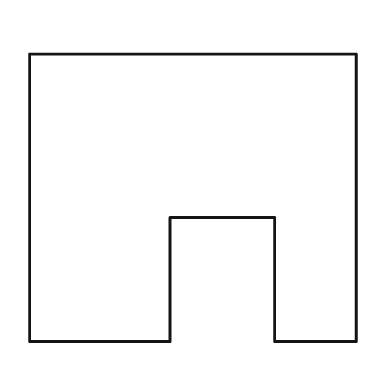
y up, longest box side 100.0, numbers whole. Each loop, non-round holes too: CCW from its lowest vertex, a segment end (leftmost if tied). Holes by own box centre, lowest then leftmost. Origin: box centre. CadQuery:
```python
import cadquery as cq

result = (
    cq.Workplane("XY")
    .moveTo(-50.0, -44.0)
    .lineTo(-7.0, -44.0)
    .lineTo(-7.0, -6.0)
    .lineTo(25.0, -6.0)
    .lineTo(25.0, -44.0)
    .lineTo(50.0, -44.0)
    .lineTo(50.0, 44.0)
    .lineTo(-50.0, 44.0)
    .close()
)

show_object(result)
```